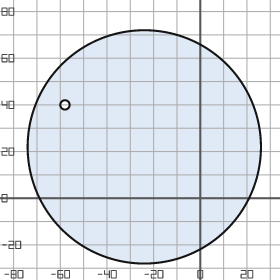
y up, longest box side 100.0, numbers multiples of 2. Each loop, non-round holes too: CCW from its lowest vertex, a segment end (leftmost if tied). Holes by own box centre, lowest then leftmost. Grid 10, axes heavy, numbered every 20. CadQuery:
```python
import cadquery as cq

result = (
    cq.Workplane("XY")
    .moveTo(-24.0, 22.0)
    .circle(50.0)
    .moveTo(-58.0, 40.0)
    .circle(2.0)
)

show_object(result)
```